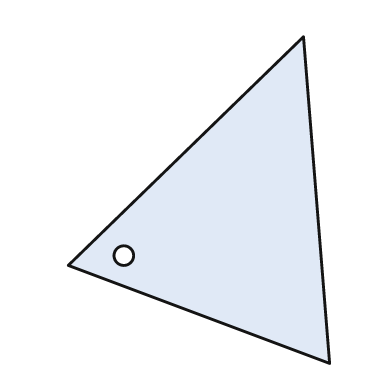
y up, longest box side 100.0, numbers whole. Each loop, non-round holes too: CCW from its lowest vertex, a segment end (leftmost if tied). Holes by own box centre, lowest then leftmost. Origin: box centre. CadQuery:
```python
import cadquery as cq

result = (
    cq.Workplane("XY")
    .moveTo(40.0, -50.0)
    .lineTo(32.0, 50.0)
    .lineTo(-40.0, -20.0)
    .close()
    .moveTo(-23.0, -17.0)
    .circle(3.0)
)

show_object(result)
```